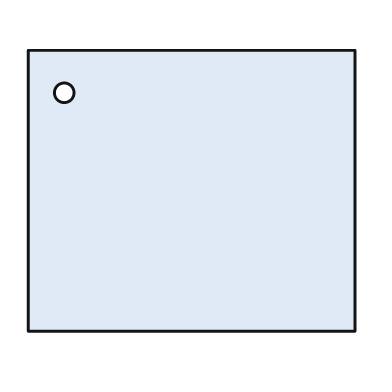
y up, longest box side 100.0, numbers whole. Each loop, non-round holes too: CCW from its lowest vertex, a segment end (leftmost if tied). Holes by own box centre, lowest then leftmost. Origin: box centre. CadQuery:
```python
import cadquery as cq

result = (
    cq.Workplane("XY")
    .moveTo(-50.0, -43.0)
    .lineTo(50.0, -43.0)
    .lineTo(50.0, 43.0)
    .lineTo(-50.0, 43.0)
    .close()
    .moveTo(-39.0, 30.0)
    .circle(3.0)
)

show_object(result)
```